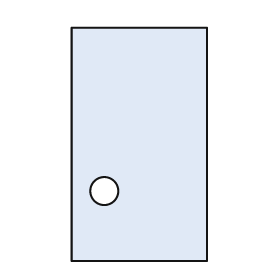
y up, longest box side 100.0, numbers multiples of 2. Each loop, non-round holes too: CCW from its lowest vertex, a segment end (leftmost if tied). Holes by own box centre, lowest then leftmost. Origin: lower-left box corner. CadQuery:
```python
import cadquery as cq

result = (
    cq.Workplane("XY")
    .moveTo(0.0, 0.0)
    .lineTo(58.0, 0.0)
    .lineTo(58.0, 100.0)
    .lineTo(0.0, 100.0)
    .close()
    .moveTo(14.0, 30.0)
    .circle(6.0)
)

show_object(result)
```